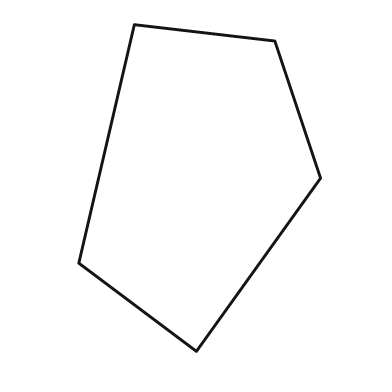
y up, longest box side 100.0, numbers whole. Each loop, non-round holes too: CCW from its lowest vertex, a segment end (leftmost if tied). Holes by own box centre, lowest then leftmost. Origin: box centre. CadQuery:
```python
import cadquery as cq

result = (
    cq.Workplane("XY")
    .moveTo(-1.0, -50.0)
    .lineTo(37.0, 3.0)
    .lineTo(23.0, 45.0)
    .lineTo(-20.0, 50.0)
    .lineTo(-37.0, -23.0)
    .close()
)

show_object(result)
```